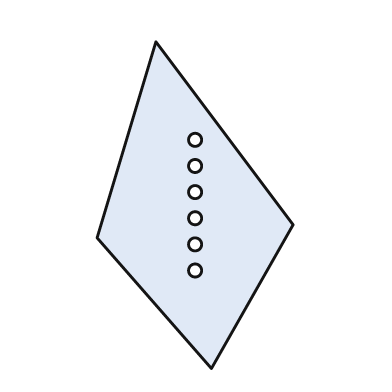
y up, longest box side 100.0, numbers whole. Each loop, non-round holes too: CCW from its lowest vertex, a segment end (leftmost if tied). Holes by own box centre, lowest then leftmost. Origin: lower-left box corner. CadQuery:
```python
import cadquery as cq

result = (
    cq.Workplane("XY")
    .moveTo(35.0, 0.0)
    .lineTo(60.0, 44.0)
    .lineTo(18.0, 100.0)
    .lineTo(0.0, 40.0)
    .close()
    .moveTo(30.0, 30.0)
    .circle(2.0)
    .moveTo(30.0, 38.0)
    .circle(2.0)
    .moveTo(30.0, 46.0)
    .circle(2.0)
    .moveTo(30.0, 54.0)
    .circle(2.0)
    .moveTo(30.0, 62.0)
    .circle(2.0)
    .moveTo(30.0, 70.0)
    .circle(2.0)
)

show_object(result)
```